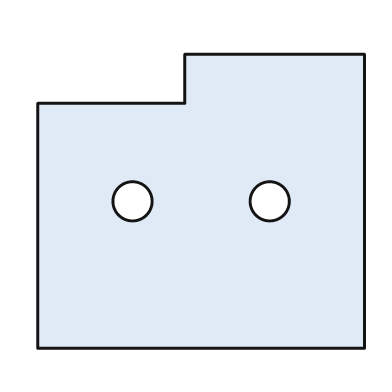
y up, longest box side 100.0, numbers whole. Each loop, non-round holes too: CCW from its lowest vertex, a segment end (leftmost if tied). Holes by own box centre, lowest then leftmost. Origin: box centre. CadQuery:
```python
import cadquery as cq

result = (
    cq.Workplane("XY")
    .moveTo(-50.0, -45.0)
    .lineTo(50.0, -45.0)
    .lineTo(50.0, 45.0)
    .lineTo(-5.0, 45.0)
    .lineTo(-5.0, 30.0)
    .lineTo(-50.0, 30.0)
    .close()
    .moveTo(-21.0, 0.0)
    .circle(6.0)
    .moveTo(21.0, 0.0)
    .circle(6.0)
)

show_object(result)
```